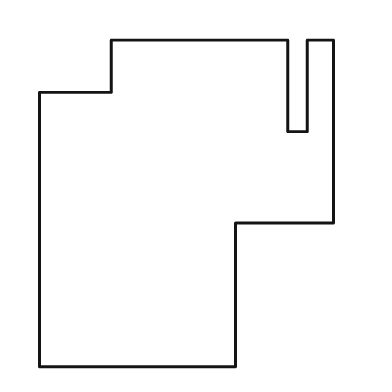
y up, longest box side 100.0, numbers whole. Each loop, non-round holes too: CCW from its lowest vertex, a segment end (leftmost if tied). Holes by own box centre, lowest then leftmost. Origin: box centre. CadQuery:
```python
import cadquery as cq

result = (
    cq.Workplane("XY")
    .moveTo(-45.0, -50.0)
    .lineTo(15.0, -50.0)
    .lineTo(15.0, -6.0)
    .lineTo(45.0, -6.0)
    .lineTo(45.0, 50.0)
    .lineTo(37.0, 50.0)
    .lineTo(37.0, 22.0)
    .lineTo(31.0, 22.0)
    .lineTo(31.0, 50.0)
    .lineTo(-23.0, 50.0)
    .lineTo(-23.0, 34.0)
    .lineTo(-45.0, 34.0)
    .close()
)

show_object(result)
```